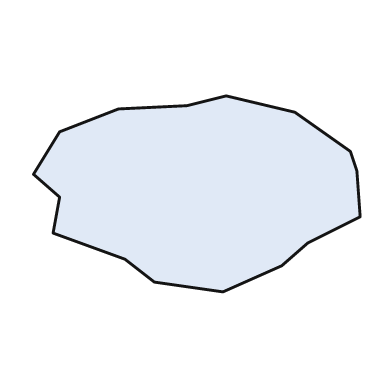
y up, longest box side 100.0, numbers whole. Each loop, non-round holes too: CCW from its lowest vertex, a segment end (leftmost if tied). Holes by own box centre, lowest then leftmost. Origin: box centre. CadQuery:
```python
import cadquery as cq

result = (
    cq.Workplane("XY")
    .moveTo(8.0, -30.0)
    .lineTo(26.0, -22.0)
    .lineTo(34.0, -15.0)
    .lineTo(50.0, -7.0)
    .lineTo(49.0, 7.0)
    .lineTo(47.0, 13.0)
    .lineTo(30.0, 25.0)
    .lineTo(9.0, 30.0)
    .lineTo(-3.0, 27.0)
    .lineTo(-24.0, 26.0)
    .lineTo(-42.0, 19.0)
    .lineTo(-50.0, 6.0)
    .lineTo(-42.0, -1.0)
    .lineTo(-44.0, -12.0)
    .lineTo(-22.0, -20.0)
    .lineTo(-13.0, -27.0)
    .close()
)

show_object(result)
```